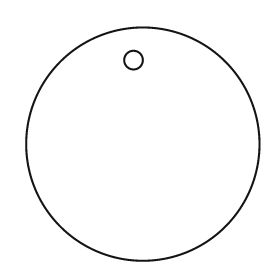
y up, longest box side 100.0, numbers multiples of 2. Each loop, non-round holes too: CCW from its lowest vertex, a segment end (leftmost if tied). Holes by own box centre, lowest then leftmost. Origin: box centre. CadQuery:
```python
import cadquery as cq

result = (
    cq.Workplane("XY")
    .moveTo(0.0, 0.0)
    .circle(50.0)
    .moveTo(-4.0, 36.0)
    .circle(4.0)
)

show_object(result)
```